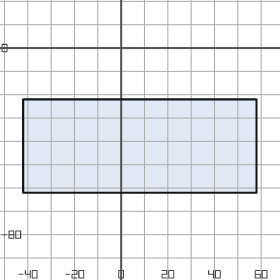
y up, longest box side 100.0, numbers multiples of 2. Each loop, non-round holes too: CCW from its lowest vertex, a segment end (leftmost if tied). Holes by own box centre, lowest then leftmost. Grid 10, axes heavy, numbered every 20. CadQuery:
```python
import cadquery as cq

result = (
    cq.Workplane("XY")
    .moveTo(-42.0, -62.0)
    .lineTo(58.0, -62.0)
    .lineTo(58.0, -22.0)
    .lineTo(-42.0, -22.0)
    .close()
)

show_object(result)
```